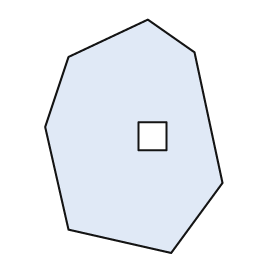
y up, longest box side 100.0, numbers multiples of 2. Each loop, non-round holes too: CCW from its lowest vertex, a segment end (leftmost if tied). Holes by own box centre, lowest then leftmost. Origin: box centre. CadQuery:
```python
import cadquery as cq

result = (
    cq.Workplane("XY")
    .moveTo(16.0, -50.0)
    .lineTo(38.0, -20.0)
    .lineTo(26.0, 36.0)
    .lineTo(6.0, 50.0)
    .lineTo(-28.0, 34.0)
    .lineTo(-38.0, 4.0)
    .lineTo(-28.0, -40.0)
    .close()
    .moveTo(2.0, -6.0)
    .lineTo(14.0, -6.0)
    .lineTo(14.0, 6.0)
    .lineTo(2.0, 6.0)
    .close()
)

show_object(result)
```